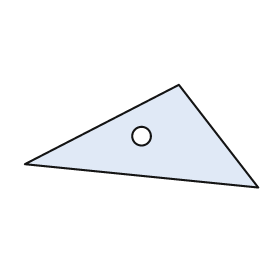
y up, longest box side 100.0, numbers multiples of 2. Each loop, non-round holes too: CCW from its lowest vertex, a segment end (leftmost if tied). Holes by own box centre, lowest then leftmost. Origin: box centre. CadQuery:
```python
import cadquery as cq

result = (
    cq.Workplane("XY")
    .moveTo(50.0, -22.0)
    .lineTo(16.0, 22.0)
    .lineTo(-50.0, -12.0)
    .close()
    .moveTo(0.0, 0.0)
    .circle(4.0)
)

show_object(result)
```